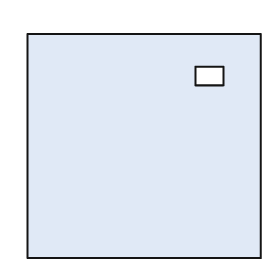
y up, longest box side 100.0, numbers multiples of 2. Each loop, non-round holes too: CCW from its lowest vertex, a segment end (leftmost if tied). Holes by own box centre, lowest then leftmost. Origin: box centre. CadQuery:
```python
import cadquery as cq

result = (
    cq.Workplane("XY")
    .moveTo(-50.0, -48.0)
    .lineTo(50.0, -48.0)
    .lineTo(50.0, 48.0)
    .lineTo(-50.0, 48.0)
    .close()
    .moveTo(22.0, 26.0)
    .lineTo(34.0, 26.0)
    .lineTo(34.0, 34.0)
    .lineTo(22.0, 34.0)
    .close()
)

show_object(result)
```